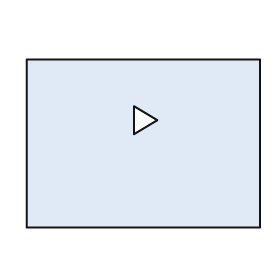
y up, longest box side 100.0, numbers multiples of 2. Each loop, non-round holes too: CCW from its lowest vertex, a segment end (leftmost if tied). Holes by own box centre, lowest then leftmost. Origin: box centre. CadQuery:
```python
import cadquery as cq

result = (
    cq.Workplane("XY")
    .moveTo(-50.0, -36.0)
    .lineTo(50.0, -36.0)
    .lineTo(50.0, 36.0)
    .lineTo(-50.0, 36.0)
    .close()
    .moveTo(-4.0, 4.0)
    .lineTo(6.0, 10.0)
    .lineTo(-4.0, 16.0)
    .close()
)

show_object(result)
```